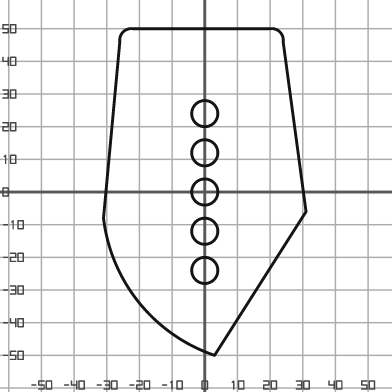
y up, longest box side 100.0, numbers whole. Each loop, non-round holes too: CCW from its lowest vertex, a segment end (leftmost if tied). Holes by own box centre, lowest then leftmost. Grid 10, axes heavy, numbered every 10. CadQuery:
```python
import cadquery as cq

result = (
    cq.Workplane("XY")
    .moveTo(3.0, -50.0)
    .lineTo(31.0, -6.0)
    .lineTo(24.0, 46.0)
    .threePointArc((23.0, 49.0), (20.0, 50.0))
    .lineTo(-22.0, 50.0)
    .threePointArc((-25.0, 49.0), (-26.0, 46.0))
    .lineTo(-31.0, -8.0)
    .threePointArc((-20.0, -34.0), (3.0, -50.0))
    .close()
    .moveTo(0.0, -24.0)
    .circle(4.0)
    .moveTo(0.0, -12.0)
    .circle(4.0)
    .moveTo(0.0, 0.0)
    .circle(4.0)
    .moveTo(0.0, 12.0)
    .circle(4.0)
    .moveTo(0.0, 24.0)
    .circle(4.0)
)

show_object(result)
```